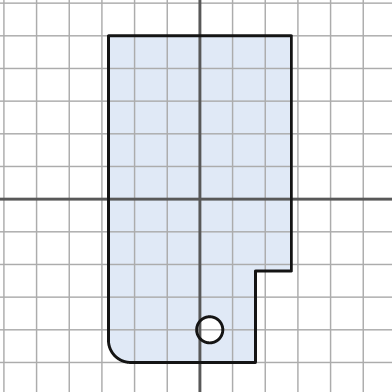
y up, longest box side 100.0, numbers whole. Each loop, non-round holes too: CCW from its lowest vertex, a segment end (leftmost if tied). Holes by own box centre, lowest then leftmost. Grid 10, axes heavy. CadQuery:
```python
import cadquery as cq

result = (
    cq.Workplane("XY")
    .moveTo(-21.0, -50.0)
    .lineTo(17.0, -50.0)
    .lineTo(17.0, -22.0)
    .lineTo(28.0, -22.0)
    .lineTo(28.0, 50.0)
    .lineTo(-28.0, 50.0)
    .lineTo(-28.0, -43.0)
    .threePointArc((-26.0, -48.0), (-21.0, -50.0))
    .close()
    .moveTo(3.0, -40.0)
    .circle(4.0)
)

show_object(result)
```